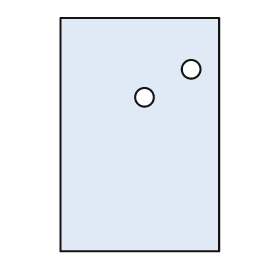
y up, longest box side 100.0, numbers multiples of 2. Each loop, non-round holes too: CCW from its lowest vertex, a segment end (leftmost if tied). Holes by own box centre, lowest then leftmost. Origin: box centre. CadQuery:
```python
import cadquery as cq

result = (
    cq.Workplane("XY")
    .moveTo(-34.0, -50.0)
    .lineTo(34.0, -50.0)
    .lineTo(34.0, 50.0)
    .lineTo(-34.0, 50.0)
    .close()
    .moveTo(2.0, 16.0)
    .circle(4.0)
    .moveTo(22.0, 28.0)
    .circle(4.0)
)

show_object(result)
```